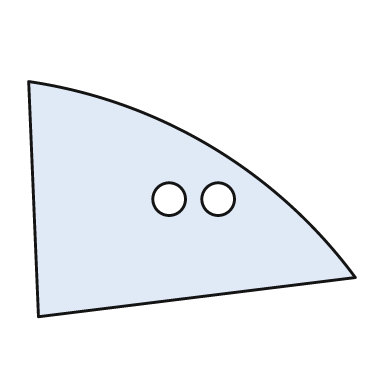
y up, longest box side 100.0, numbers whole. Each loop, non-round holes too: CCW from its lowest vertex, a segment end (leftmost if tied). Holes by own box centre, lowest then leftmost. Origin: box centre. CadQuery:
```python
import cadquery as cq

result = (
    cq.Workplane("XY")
    .moveTo(-47.0, -36.0)
    .lineTo(50.0, -24.0)
    .threePointArc((6.0, 16.0), (-50.0, 36.0))
    .close()
    .moveTo(-7.0, 0.0)
    .circle(5.0)
    .moveTo(8.0, 0.0)
    .circle(5.0)
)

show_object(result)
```